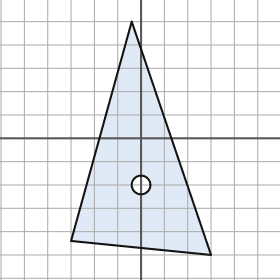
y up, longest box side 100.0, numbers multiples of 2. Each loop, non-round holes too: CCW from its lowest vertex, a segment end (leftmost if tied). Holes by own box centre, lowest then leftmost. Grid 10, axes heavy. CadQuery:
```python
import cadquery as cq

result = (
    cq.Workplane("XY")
    .moveTo(30.0, -50.0)
    .lineTo(-4.0, 50.0)
    .lineTo(-30.0, -44.0)
    .close()
    .moveTo(0.0, -20.0)
    .circle(4.0)
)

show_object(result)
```